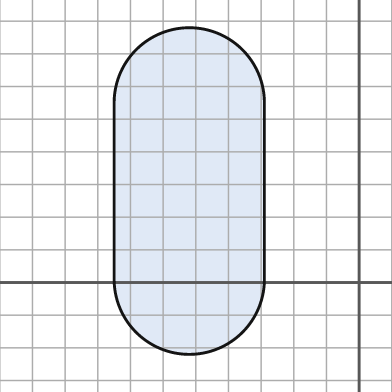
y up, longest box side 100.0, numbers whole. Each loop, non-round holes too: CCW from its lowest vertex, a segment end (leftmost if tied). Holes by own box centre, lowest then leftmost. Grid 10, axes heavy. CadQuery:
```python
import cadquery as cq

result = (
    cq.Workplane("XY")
    .moveTo(-75.0, 1.0)
    .threePointArc((-52.0, -22.0), (-29.0, 1.0))
    .lineTo(-29.0, 55.0)
    .threePointArc((-52.0, 78.0), (-75.0, 55.0))
    .close()
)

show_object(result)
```